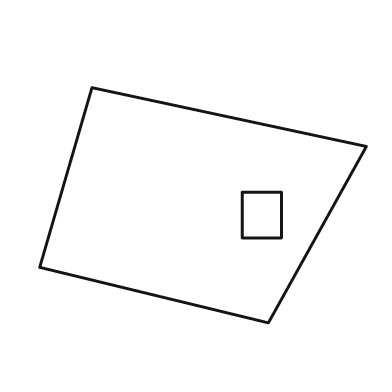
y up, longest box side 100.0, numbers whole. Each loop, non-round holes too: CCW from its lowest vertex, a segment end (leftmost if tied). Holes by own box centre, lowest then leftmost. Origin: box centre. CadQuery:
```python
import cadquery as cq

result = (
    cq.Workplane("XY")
    .moveTo(20.0, -36.0)
    .lineTo(50.0, 18.0)
    .lineTo(-34.0, 36.0)
    .lineTo(-50.0, -19.0)
    .close()
    .moveTo(12.0, -10.0)
    .lineTo(24.0, -10.0)
    .lineTo(24.0, 4.0)
    .lineTo(12.0, 4.0)
    .close()
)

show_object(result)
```